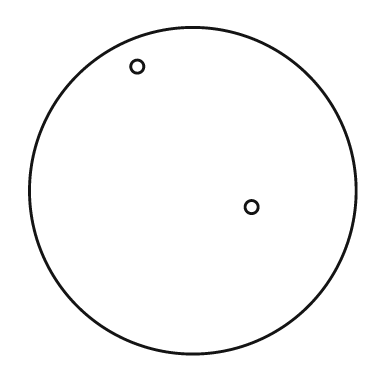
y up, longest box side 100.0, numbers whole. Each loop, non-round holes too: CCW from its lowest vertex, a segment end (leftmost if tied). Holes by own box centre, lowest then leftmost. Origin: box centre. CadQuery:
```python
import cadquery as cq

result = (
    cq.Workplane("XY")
    .moveTo(0.0, 0.0)
    .circle(50.0)
    .moveTo(18.0, -5.0)
    .circle(2.0)
    .moveTo(-17.0, 38.0)
    .circle(2.0)
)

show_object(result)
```